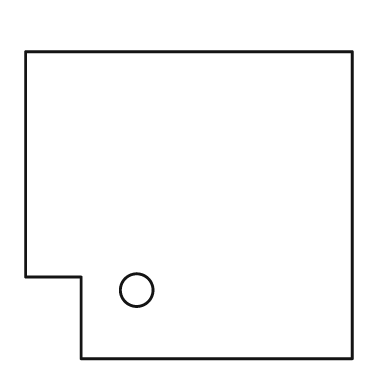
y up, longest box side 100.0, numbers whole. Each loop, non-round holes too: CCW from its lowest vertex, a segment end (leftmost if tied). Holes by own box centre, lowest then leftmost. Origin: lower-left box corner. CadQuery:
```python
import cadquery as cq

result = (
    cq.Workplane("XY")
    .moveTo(17.0, 0.0)
    .lineTo(100.0, 0.0)
    .lineTo(100.0, 94.0)
    .lineTo(0.0, 94.0)
    .lineTo(0.0, 25.0)
    .lineTo(17.0, 25.0)
    .close()
    .moveTo(34.0, 21.0)
    .circle(5.0)
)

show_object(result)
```